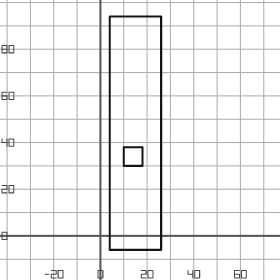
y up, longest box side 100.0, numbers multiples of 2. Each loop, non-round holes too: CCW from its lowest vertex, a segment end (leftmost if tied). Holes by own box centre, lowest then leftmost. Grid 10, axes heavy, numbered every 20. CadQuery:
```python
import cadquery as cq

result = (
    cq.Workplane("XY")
    .moveTo(4.0, -6.0)
    .lineTo(26.0, -6.0)
    .lineTo(26.0, 94.0)
    .lineTo(4.0, 94.0)
    .close()
    .moveTo(10.0, 30.0)
    .lineTo(18.0, 30.0)
    .lineTo(18.0, 38.0)
    .lineTo(10.0, 38.0)
    .close()
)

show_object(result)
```